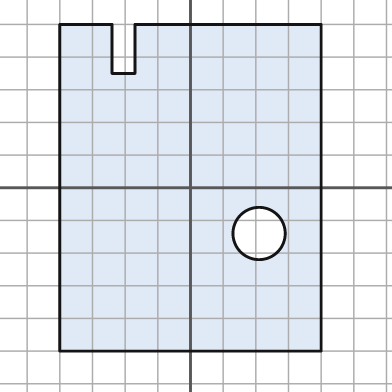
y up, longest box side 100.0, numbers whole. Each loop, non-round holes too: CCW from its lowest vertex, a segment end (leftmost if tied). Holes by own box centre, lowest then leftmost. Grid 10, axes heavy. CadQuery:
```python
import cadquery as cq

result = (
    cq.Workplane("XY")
    .moveTo(-40.0, -50.0)
    .lineTo(40.0, -50.0)
    .lineTo(40.0, 50.0)
    .lineTo(-17.0, 50.0)
    .lineTo(-17.0, 35.0)
    .lineTo(-24.0, 35.0)
    .lineTo(-24.0, 50.0)
    .lineTo(-40.0, 50.0)
    .close()
    .moveTo(21.0, -14.0)
    .circle(8.0)
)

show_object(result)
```